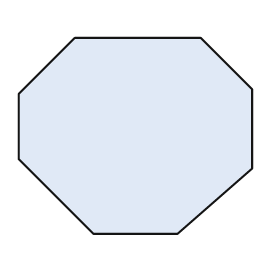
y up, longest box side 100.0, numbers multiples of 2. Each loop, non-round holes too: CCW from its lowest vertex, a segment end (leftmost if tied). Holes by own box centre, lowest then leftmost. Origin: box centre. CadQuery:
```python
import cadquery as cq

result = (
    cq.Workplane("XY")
    .moveTo(-18.0, -42.0)
    .lineTo(18.0, -42.0)
    .lineTo(50.0, -14.0)
    .lineTo(50.0, 20.0)
    .lineTo(28.0, 42.0)
    .lineTo(-26.0, 42.0)
    .lineTo(-50.0, 18.0)
    .lineTo(-50.0, -10.0)
    .close()
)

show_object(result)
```